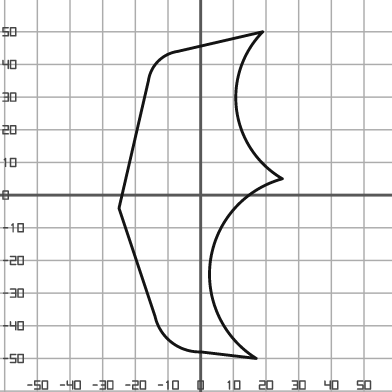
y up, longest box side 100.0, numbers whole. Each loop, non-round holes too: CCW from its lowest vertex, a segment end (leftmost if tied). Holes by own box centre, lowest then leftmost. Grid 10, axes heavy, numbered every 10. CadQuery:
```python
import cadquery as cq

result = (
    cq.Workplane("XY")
    .moveTo(17.0, -50.0)
    .threePointArc((3.0, -20.0), (25.0, 5.0))
    .threePointArc((11.0, 26.0), (19.0, 50.0))
    .lineTo(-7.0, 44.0)
    .threePointArc((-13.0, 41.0), (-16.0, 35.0))
    .lineTo(-25.0, -4.0)
    .lineTo(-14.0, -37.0)
    .threePointArc((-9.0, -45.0), (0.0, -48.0))
    .close()
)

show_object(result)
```